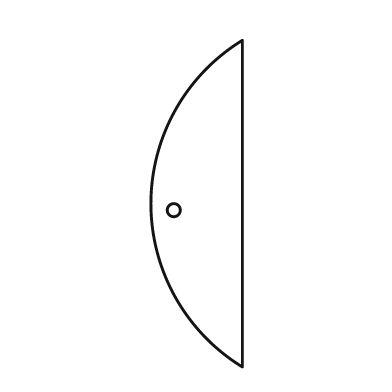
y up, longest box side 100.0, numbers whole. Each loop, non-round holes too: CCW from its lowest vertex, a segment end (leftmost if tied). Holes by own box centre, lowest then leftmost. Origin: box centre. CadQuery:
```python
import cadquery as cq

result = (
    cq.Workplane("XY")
    .moveTo(14.0, -50.0)
    .lineTo(14.0, 50.0)
    .threePointArc((-14.0, 0.0), (14.0, -50.0))
    .close()
    .moveTo(-7.0, -2.0)
    .circle(2.0)
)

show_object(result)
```